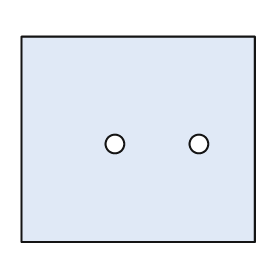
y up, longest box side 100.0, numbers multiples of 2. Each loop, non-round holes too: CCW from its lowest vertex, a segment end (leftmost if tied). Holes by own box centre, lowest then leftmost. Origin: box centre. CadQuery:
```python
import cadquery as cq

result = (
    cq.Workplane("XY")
    .moveTo(-50.0, -44.0)
    .lineTo(50.0, -44.0)
    .lineTo(50.0, 44.0)
    .lineTo(-50.0, 44.0)
    .close()
    .moveTo(-10.0, -2.0)
    .circle(4.0)
    .moveTo(26.0, -2.0)
    .circle(4.0)
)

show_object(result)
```